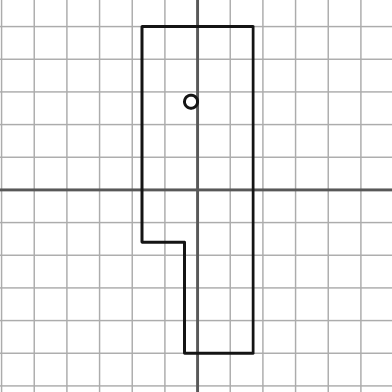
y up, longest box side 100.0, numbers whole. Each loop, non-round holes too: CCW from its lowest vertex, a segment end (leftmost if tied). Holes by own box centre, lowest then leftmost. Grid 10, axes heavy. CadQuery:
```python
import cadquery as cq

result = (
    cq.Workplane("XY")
    .moveTo(-4.0, -50.0)
    .lineTo(17.0, -50.0)
    .lineTo(17.0, 50.0)
    .lineTo(-17.0, 50.0)
    .lineTo(-17.0, -16.0)
    .lineTo(-4.0, -16.0)
    .close()
    .moveTo(-2.0, 27.0)
    .circle(2.0)
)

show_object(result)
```